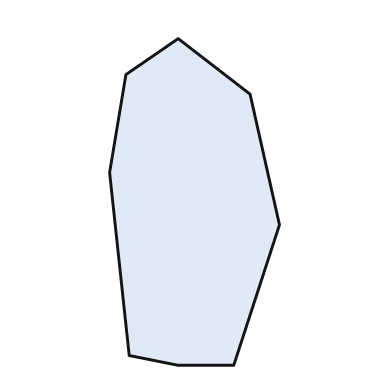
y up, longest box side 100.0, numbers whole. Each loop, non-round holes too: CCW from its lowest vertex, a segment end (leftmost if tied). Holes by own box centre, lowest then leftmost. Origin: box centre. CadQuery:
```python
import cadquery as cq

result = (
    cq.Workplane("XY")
    .moveTo(-5.0, -50.0)
    .lineTo(12.0, -50.0)
    .lineTo(26.0, -7.0)
    .lineTo(17.0, 33.0)
    .lineTo(-5.0, 50.0)
    .lineTo(-21.0, 39.0)
    .lineTo(-26.0, 9.0)
    .lineTo(-20.0, -47.0)
    .close()
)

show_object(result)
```